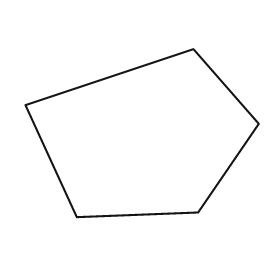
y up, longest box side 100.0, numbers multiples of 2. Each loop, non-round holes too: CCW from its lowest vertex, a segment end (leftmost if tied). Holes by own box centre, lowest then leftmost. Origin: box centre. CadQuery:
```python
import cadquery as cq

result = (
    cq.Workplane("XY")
    .moveTo(-28.0, -36.0)
    .lineTo(24.0, -34.0)
    .lineTo(50.0, 4.0)
    .lineTo(22.0, 36.0)
    .lineTo(-50.0, 12.0)
    .close()
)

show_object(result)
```